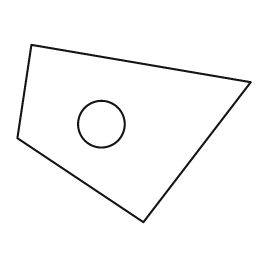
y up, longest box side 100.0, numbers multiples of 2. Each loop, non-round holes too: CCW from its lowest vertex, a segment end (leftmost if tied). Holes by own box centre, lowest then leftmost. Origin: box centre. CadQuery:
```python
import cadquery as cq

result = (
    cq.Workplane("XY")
    .moveTo(4.0, -38.0)
    .lineTo(50.0, 22.0)
    .lineTo(-44.0, 38.0)
    .lineTo(-50.0, -2.0)
    .close()
    .moveTo(-14.0, 4.0)
    .circle(10.0)
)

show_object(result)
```